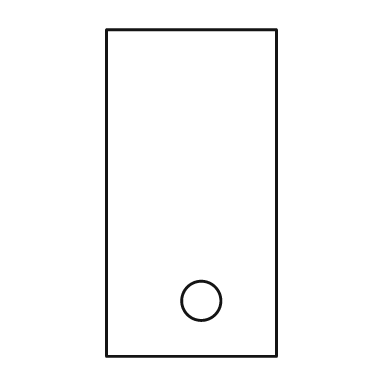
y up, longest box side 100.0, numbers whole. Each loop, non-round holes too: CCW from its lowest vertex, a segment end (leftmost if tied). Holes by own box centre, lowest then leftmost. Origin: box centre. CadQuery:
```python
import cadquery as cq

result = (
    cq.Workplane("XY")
    .moveTo(-26.0, -50.0)
    .lineTo(26.0, -50.0)
    .lineTo(26.0, 50.0)
    .lineTo(-26.0, 50.0)
    .close()
    .moveTo(3.0, -33.0)
    .circle(6.0)
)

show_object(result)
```